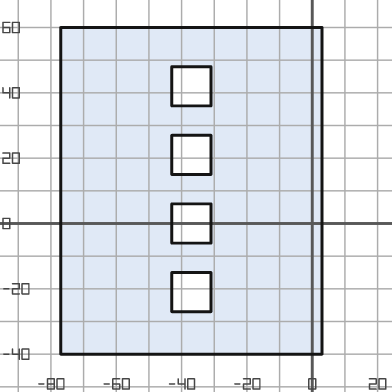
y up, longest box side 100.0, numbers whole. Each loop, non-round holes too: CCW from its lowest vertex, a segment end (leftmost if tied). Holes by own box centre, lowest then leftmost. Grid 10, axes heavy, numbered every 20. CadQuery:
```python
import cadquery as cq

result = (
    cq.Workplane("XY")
    .moveTo(-77.0, -40.0)
    .lineTo(3.0, -40.0)
    .lineTo(3.0, 60.0)
    .lineTo(-77.0, 60.0)
    .close()
    .moveTo(-43.0, -27.0)
    .lineTo(-31.0, -27.0)
    .lineTo(-31.0, -15.0)
    .lineTo(-43.0, -15.0)
    .close()
    .moveTo(-43.0, -6.0)
    .lineTo(-31.0, -6.0)
    .lineTo(-31.0, 6.0)
    .lineTo(-43.0, 6.0)
    .close()
    .moveTo(-43.0, 15.0)
    .lineTo(-31.0, 15.0)
    .lineTo(-31.0, 27.0)
    .lineTo(-43.0, 27.0)
    .close()
    .moveTo(-43.0, 36.0)
    .lineTo(-31.0, 36.0)
    .lineTo(-31.0, 48.0)
    .lineTo(-43.0, 48.0)
    .close()
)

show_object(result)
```